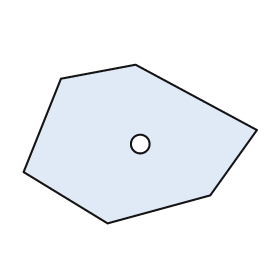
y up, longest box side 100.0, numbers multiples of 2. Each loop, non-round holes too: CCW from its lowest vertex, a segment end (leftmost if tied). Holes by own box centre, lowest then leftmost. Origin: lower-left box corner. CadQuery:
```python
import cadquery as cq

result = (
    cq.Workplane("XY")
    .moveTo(36.0, 0.0)
    .lineTo(80.0, 12.0)
    .lineTo(100.0, 40.0)
    .lineTo(48.0, 68.0)
    .lineTo(16.0, 62.0)
    .lineTo(0.0, 22.0)
    .close()
    .moveTo(50.0, 34.0)
    .circle(4.0)
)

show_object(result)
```